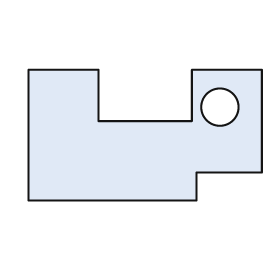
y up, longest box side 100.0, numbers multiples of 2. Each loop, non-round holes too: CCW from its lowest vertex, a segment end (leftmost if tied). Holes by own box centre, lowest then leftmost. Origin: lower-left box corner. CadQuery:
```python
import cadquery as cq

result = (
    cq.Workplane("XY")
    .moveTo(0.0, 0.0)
    .lineTo(72.0, 0.0)
    .lineTo(72.0, 12.0)
    .lineTo(100.0, 12.0)
    .lineTo(100.0, 56.0)
    .lineTo(70.0, 56.0)
    .lineTo(70.0, 34.0)
    .lineTo(30.0, 34.0)
    .lineTo(30.0, 56.0)
    .lineTo(0.0, 56.0)
    .close()
    .moveTo(82.0, 40.0)
    .circle(8.0)
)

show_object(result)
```